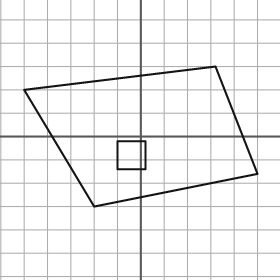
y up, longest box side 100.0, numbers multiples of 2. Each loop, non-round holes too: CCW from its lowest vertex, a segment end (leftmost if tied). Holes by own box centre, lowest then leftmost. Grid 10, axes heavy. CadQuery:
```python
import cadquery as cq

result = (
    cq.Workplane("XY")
    .moveTo(-20.0, -30.0)
    .lineTo(50.0, -16.0)
    .lineTo(32.0, 30.0)
    .lineTo(-50.0, 20.0)
    .close()
    .moveTo(-10.0, -14.0)
    .lineTo(2.0, -14.0)
    .lineTo(2.0, -2.0)
    .lineTo(-10.0, -2.0)
    .close()
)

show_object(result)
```